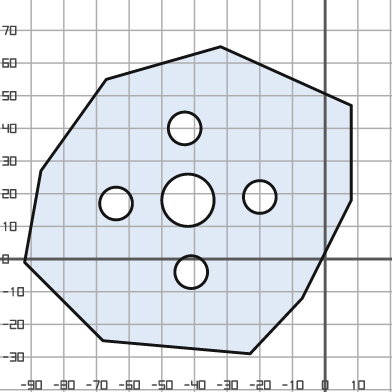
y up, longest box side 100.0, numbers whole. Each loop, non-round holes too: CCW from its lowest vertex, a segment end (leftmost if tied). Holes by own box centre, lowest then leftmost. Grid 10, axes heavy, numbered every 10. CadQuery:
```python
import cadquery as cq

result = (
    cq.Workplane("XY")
    .moveTo(-23.0, -29.0)
    .lineTo(-7.0, -12.0)
    .lineTo(8.0, 18.0)
    .lineTo(8.0, 47.0)
    .lineTo(-32.0, 65.0)
    .lineTo(-67.0, 55.0)
    .lineTo(-87.0, 27.0)
    .lineTo(-92.0, -1.0)
    .lineTo(-68.0, -25.0)
    .close()
    .moveTo(-41.0, -4.0)
    .circle(5.0)
    .moveTo(-64.0, 17.0)
    .circle(5.0)
    .moveTo(-42.0, 18.0)
    .circle(8.0)
    .moveTo(-20.0, 19.0)
    .circle(5.0)
    .moveTo(-43.0, 40.0)
    .circle(5.0)
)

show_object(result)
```